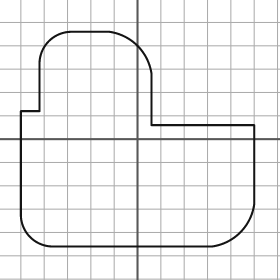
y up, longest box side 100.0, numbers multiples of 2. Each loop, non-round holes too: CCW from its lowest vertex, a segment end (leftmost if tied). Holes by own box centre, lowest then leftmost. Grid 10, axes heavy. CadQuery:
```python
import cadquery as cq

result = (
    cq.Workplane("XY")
    .moveTo(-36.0, -46.0)
    .lineTo(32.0, -46.0)
    .threePointArc((44.0, -40.0), (50.0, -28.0))
    .lineTo(50.0, 6.0)
    .lineTo(6.0, 6.0)
    .lineTo(6.0, 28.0)
    .threePointArc((0.0, 40.0), (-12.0, 46.0))
    .lineTo(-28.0, 46.0)
    .threePointArc((-38.0, 42.0), (-42.0, 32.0))
    .lineTo(-42.0, 12.0)
    .lineTo(-50.0, 12.0)
    .lineTo(-50.0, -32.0)
    .threePointArc((-46.0, -42.0), (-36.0, -46.0))
    .close()
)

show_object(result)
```